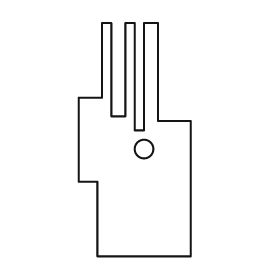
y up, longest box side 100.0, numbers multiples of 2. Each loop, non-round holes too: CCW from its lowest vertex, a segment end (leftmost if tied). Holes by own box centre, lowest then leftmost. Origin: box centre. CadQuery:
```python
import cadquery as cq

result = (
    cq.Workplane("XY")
    .moveTo(-16.0, -50.0)
    .lineTo(24.0, -50.0)
    .lineTo(24.0, 8.0)
    .lineTo(10.0, 8.0)
    .lineTo(10.0, 50.0)
    .lineTo(4.0, 50.0)
    .lineTo(4.0, 4.0)
    .lineTo(0.0, 4.0)
    .lineTo(0.0, 50.0)
    .lineTo(-4.0, 50.0)
    .lineTo(-4.0, 10.0)
    .lineTo(-10.0, 10.0)
    .lineTo(-10.0, 50.0)
    .lineTo(-14.0, 50.0)
    .lineTo(-14.0, 18.0)
    .lineTo(-24.0, 18.0)
    .lineTo(-24.0, -18.0)
    .lineTo(-16.0, -18.0)
    .close()
    .moveTo(4.0, -4.0)
    .circle(4.0)
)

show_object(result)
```